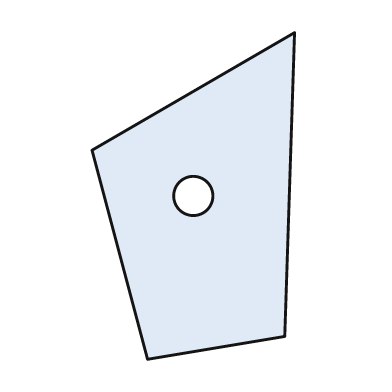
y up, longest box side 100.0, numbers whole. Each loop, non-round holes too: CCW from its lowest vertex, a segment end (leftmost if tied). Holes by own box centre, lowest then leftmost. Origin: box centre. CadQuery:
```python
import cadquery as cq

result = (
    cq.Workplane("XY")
    .moveTo(-14.0, -50.0)
    .lineTo(28.0, -43.0)
    .lineTo(31.0, 50.0)
    .lineTo(-31.0, 14.0)
    .close()
    .moveTo(0.0, 0.0)
    .circle(6.0)
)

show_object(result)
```